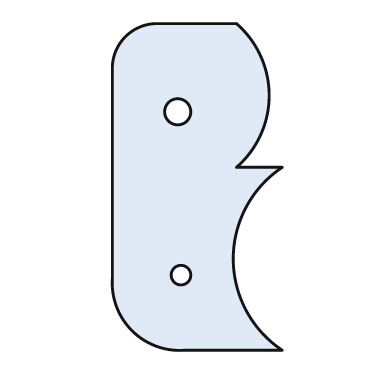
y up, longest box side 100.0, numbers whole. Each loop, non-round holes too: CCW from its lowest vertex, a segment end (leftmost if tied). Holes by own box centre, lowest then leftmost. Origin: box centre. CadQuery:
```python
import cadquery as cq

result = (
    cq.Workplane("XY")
    .moveTo(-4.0, -50.0)
    .lineTo(26.0, -50.0)
    .threePointArc((11.0, -22.0), (26.0, 6.0))
    .lineTo(12.0, 6.0)
    .threePointArc((22.0, 28.0), (12.0, 50.0))
    .lineTo(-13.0, 50.0)
    .threePointArc((-22.0, 46.0), (-26.0, 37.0))
    .lineTo(-26.0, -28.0)
    .threePointArc((-20.0, -44.0), (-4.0, -50.0))
    .close()
    .moveTo(-5.0, -27.0)
    .circle(3.0)
    .moveTo(-6.0, 23.0)
    .circle(4.0)
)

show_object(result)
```